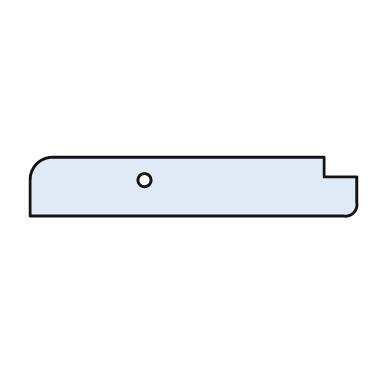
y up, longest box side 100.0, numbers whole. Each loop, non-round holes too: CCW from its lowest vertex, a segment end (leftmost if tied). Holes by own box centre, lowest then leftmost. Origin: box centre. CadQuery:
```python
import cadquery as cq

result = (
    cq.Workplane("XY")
    .moveTo(-50.0, -9.0)
    .lineTo(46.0, -9.0)
    .threePointArc((49.0, -8.0), (50.0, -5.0))
    .lineTo(50.0, 3.0)
    .lineTo(40.0, 3.0)
    .lineTo(40.0, 9.0)
    .lineTo(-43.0, 9.0)
    .threePointArc((-48.0, 7.0), (-50.0, 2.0))
    .close()
    .moveTo(-15.0, 2.0)
    .circle(2.0)
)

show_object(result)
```